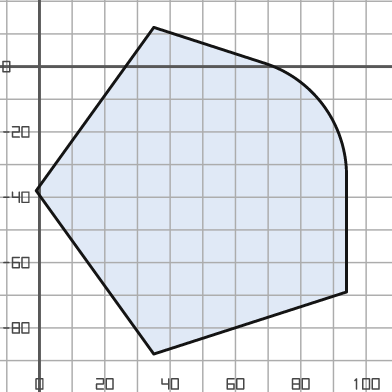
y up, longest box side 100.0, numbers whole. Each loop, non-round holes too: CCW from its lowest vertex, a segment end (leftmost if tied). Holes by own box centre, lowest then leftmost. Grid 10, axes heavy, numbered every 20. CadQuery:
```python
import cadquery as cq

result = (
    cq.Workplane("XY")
    .moveTo(35.0, -88.0)
    .lineTo(94.0, -69.0)
    .lineTo(94.0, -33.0)
    .threePointArc((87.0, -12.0), (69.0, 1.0))
    .lineTo(35.0, 12.0)
    .lineTo(-1.0, -38.0)
    .close()
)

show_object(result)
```